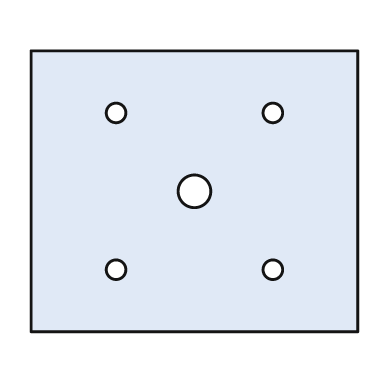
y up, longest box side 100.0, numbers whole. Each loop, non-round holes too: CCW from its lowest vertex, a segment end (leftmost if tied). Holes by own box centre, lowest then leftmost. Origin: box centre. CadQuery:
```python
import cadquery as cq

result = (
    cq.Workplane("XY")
    .moveTo(-50.0, -43.0)
    .lineTo(50.0, -43.0)
    .lineTo(50.0, 43.0)
    .lineTo(-50.0, 43.0)
    .close()
    .moveTo(-24.0, -24.0)
    .circle(3.0)
    .moveTo(24.0, -24.0)
    .circle(3.0)
    .moveTo(0.0, 0.0)
    .circle(5.0)
    .moveTo(-24.0, 24.0)
    .circle(3.0)
    .moveTo(24.0, 24.0)
    .circle(3.0)
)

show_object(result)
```